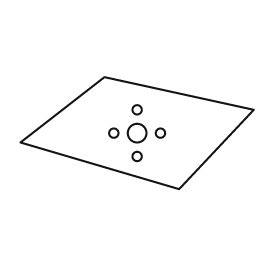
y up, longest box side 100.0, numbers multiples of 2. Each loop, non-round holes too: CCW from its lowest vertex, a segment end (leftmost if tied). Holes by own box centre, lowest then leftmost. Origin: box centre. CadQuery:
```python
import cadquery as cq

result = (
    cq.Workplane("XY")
    .moveTo(18.0, -24.0)
    .lineTo(50.0, 10.0)
    .lineTo(-14.0, 24.0)
    .lineTo(-50.0, -4.0)
    .close()
    .moveTo(0.0, -10.0)
    .circle(2.0)
    .moveTo(-10.0, 0.0)
    .circle(2.0)
    .moveTo(0.0, 0.0)
    .circle(4.0)
    .moveTo(10.0, 0.0)
    .circle(2.0)
    .moveTo(0.0, 10.0)
    .circle(2.0)
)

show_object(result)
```